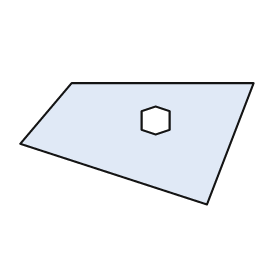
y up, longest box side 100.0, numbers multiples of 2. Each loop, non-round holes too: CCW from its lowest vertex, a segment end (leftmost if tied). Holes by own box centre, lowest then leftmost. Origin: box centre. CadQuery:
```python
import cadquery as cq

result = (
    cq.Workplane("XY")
    .moveTo(30.0, -26.0)
    .lineTo(50.0, 26.0)
    .lineTo(-28.0, 26.0)
    .lineTo(-50.0, 0.0)
    .close()
    .moveTo(8.0, 4.0)
    .lineTo(14.0, 6.0)
    .lineTo(14.0, 14.0)
    .lineTo(8.0, 16.0)
    .lineTo(2.0, 14.0)
    .lineTo(2.0, 6.0)
    .close()
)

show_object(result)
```